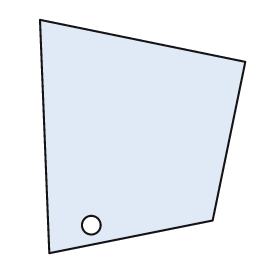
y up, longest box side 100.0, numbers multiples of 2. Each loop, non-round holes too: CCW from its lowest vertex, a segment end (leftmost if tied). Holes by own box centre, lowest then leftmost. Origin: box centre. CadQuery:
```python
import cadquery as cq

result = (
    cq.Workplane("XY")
    .moveTo(-40.0, -50.0)
    .lineTo(30.0, -36.0)
    .lineTo(44.0, 32.0)
    .lineTo(-44.0, 50.0)
    .close()
    .moveTo(-22.0, -38.0)
    .circle(4.0)
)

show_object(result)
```